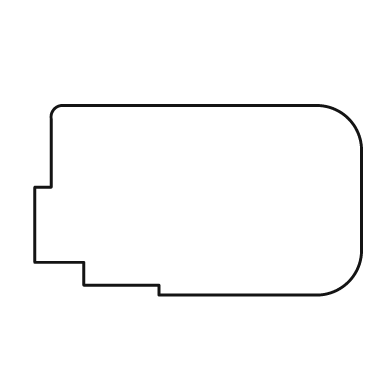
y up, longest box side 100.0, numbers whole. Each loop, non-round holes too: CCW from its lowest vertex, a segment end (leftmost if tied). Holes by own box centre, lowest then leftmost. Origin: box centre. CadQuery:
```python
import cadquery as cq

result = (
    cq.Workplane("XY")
    .moveTo(-12.0, -29.0)
    .lineTo(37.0, -29.0)
    .threePointArc((46.0, -25.0), (50.0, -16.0))
    .lineTo(50.0, 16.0)
    .threePointArc((46.0, 25.0), (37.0, 29.0))
    .lineTo(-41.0, 29.0)
    .threePointArc((-44.0, 28.0), (-45.0, 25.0))
    .lineTo(-45.0, 4.0)
    .lineTo(-50.0, 4.0)
    .lineTo(-50.0, -19.0)
    .lineTo(-35.0, -19.0)
    .lineTo(-35.0, -26.0)
    .lineTo(-12.0, -26.0)
    .close()
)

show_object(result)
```